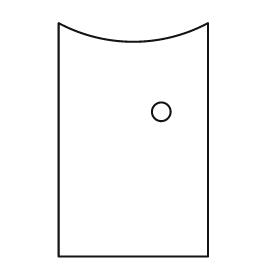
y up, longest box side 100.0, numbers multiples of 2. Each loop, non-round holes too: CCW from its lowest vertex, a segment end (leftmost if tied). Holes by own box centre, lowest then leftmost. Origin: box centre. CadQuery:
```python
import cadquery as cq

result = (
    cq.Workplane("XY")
    .moveTo(-32.0, -50.0)
    .lineTo(32.0, -50.0)
    .lineTo(32.0, 50.0)
    .threePointArc((0.0, 42.0), (-32.0, 50.0))
    .close()
    .moveTo(12.0, 12.0)
    .circle(4.0)
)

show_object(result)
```